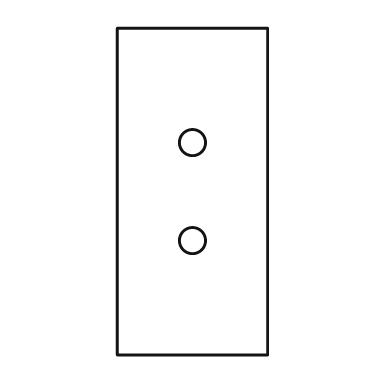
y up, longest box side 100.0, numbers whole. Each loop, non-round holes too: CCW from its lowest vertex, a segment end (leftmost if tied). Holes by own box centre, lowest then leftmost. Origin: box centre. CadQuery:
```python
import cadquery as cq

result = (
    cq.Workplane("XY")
    .moveTo(-23.0, -50.0)
    .lineTo(23.0, -50.0)
    .lineTo(23.0, 50.0)
    .lineTo(-23.0, 50.0)
    .close()
    .moveTo(0.0, -15.0)
    .circle(4.0)
    .moveTo(0.0, 15.0)
    .circle(4.0)
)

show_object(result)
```